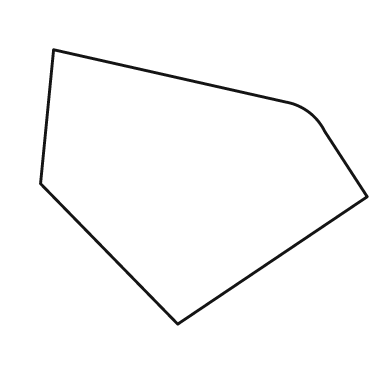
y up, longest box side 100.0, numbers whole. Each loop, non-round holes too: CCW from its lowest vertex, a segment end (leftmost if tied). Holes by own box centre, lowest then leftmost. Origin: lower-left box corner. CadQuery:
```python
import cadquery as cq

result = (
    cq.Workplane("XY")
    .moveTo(42.0, 0.0)
    .lineTo(100.0, 39.0)
    .lineTo(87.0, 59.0)
    .threePointArc((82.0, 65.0), (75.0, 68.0))
    .lineTo(4.0, 84.0)
    .lineTo(0.0, 43.0)
    .close()
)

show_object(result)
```